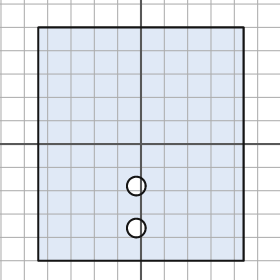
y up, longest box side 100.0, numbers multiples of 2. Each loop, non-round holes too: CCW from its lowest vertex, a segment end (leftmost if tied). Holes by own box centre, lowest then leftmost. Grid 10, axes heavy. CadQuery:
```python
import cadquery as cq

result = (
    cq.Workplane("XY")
    .moveTo(-44.0, -50.0)
    .lineTo(44.0, -50.0)
    .lineTo(44.0, 50.0)
    .lineTo(-44.0, 50.0)
    .close()
    .moveTo(-2.0, -36.0)
    .circle(4.0)
    .moveTo(-2.0, -18.0)
    .circle(4.0)
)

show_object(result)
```